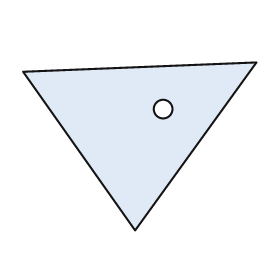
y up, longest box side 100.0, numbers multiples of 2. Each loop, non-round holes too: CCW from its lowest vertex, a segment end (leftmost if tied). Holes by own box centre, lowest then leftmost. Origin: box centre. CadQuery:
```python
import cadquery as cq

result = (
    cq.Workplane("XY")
    .moveTo(-2.0, -36.0)
    .lineTo(50.0, 36.0)
    .lineTo(-50.0, 32.0)
    .close()
    .moveTo(10.0, 16.0)
    .circle(4.0)
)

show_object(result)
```